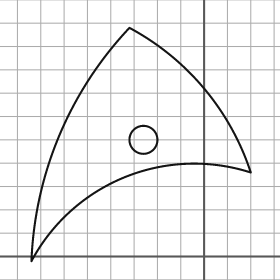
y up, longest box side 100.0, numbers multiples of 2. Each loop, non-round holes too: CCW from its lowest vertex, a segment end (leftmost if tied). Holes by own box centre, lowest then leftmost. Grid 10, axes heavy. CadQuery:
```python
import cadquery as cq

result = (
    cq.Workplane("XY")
    .moveTo(-74.0, -2.0)
    .threePointArc((-34.0, 34.0), (20.0, 36.0))
    .threePointArc((0.0, 72.0), (-32.0, 98.0))
    .threePointArc((-62.0, 52.0), (-74.0, -2.0))
    .close()
    .moveTo(-26.0, 50.0)
    .circle(6.0)
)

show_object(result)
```